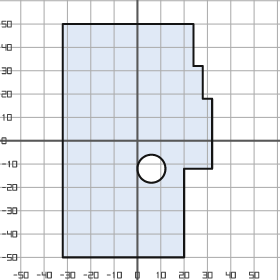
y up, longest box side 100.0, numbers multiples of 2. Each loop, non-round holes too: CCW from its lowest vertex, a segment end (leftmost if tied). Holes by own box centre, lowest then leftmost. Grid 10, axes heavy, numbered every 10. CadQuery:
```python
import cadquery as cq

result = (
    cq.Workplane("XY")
    .moveTo(-32.0, -50.0)
    .lineTo(20.0, -50.0)
    .lineTo(20.0, -12.0)
    .lineTo(32.0, -12.0)
    .lineTo(32.0, 18.0)
    .lineTo(28.0, 18.0)
    .lineTo(28.0, 32.0)
    .lineTo(24.0, 32.0)
    .lineTo(24.0, 50.0)
    .lineTo(-32.0, 50.0)
    .close()
    .moveTo(6.0, -12.0)
    .circle(6.0)
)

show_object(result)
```